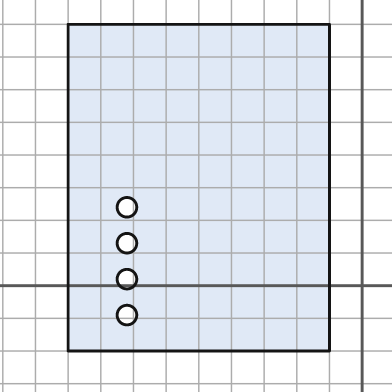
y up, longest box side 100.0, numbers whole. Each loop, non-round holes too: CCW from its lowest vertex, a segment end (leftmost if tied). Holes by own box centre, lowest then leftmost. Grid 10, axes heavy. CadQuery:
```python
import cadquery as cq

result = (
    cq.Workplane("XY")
    .moveTo(-90.0, -20.0)
    .lineTo(-10.0, -20.0)
    .lineTo(-10.0, 80.0)
    .lineTo(-90.0, 80.0)
    .close()
    .moveTo(-72.0, -9.0)
    .circle(3.0)
    .moveTo(-72.0, 2.0)
    .circle(3.0)
    .moveTo(-72.0, 13.0)
    .circle(3.0)
    .moveTo(-72.0, 24.0)
    .circle(3.0)
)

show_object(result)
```